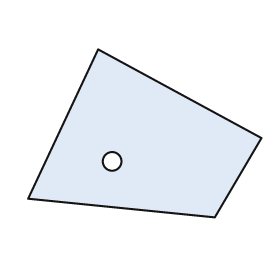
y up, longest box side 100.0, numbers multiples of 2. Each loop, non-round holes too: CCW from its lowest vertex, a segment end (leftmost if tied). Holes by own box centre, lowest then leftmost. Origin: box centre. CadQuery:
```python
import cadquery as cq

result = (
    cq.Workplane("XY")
    .moveTo(30.0, -36.0)
    .lineTo(50.0, -2.0)
    .lineTo(-20.0, 36.0)
    .lineTo(-50.0, -28.0)
    .close()
    .moveTo(-14.0, -12.0)
    .circle(4.0)
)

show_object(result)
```